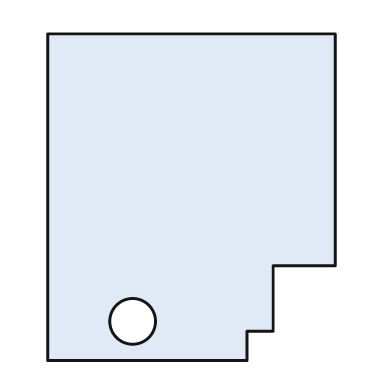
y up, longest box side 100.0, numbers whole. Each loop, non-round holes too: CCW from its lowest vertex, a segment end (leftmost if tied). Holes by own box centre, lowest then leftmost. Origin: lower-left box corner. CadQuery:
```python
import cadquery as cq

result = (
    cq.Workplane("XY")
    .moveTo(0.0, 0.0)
    .lineTo(61.0, 0.0)
    .lineTo(61.0, 9.0)
    .lineTo(69.0, 9.0)
    .lineTo(69.0, 29.0)
    .lineTo(88.0, 29.0)
    .lineTo(88.0, 100.0)
    .lineTo(0.0, 100.0)
    .close()
    .moveTo(26.0, 12.0)
    .circle(7.0)
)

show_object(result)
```